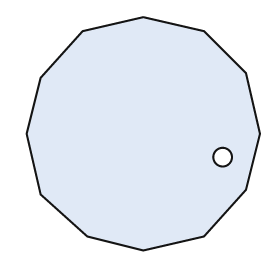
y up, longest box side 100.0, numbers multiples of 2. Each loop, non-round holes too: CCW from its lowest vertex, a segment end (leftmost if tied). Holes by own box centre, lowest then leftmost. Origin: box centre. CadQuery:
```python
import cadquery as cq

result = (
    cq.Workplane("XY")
    .moveTo(0.0, -50.0)
    .lineTo(26.0, -44.0)
    .lineTo(44.0, -24.0)
    .lineTo(50.0, 0.0)
    .lineTo(44.0, 26.0)
    .lineTo(26.0, 44.0)
    .lineTo(0.0, 50.0)
    .lineTo(-26.0, 44.0)
    .lineTo(-44.0, 24.0)
    .lineTo(-50.0, 0.0)
    .lineTo(-44.0, -26.0)
    .lineTo(-24.0, -44.0)
    .close()
    .moveTo(34.0, -10.0)
    .circle(4.0)
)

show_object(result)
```